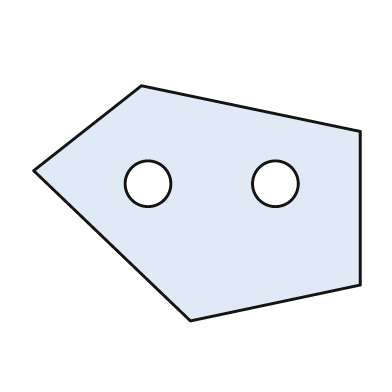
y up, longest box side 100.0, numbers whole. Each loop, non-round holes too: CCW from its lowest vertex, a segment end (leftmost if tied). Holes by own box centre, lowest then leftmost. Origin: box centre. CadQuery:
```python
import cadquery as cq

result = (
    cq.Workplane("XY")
    .moveTo(-2.0, -36.0)
    .lineTo(50.0, -25.0)
    .lineTo(50.0, 22.0)
    .lineTo(-17.0, 36.0)
    .lineTo(-50.0, 10.0)
    .close()
    .moveTo(-15.0, 6.0)
    .circle(7.0)
    .moveTo(24.0, 6.0)
    .circle(7.0)
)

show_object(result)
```